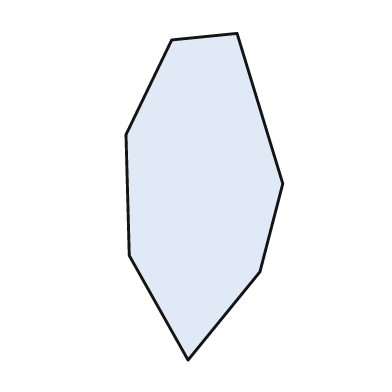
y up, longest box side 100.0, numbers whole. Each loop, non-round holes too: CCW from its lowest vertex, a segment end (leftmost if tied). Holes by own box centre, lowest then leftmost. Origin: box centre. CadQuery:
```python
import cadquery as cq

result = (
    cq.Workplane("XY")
    .moveTo(-5.0, -50.0)
    .lineTo(17.0, -23.0)
    .lineTo(24.0, 4.0)
    .lineTo(10.0, 50.0)
    .lineTo(-10.0, 48.0)
    .lineTo(-24.0, 19.0)
    .lineTo(-23.0, -18.0)
    .close()
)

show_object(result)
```